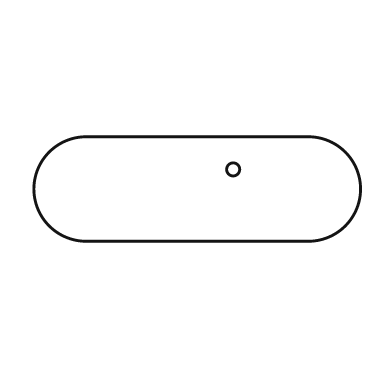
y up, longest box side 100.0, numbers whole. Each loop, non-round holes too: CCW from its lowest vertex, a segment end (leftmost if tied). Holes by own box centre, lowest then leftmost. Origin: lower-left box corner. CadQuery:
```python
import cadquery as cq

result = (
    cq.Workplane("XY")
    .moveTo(16.0, 0.0)
    .lineTo(84.0, 0.0)
    .threePointArc((100.0, 16.0), (84.0, 32.0))
    .lineTo(16.0, 32.0)
    .threePointArc((0.0, 16.0), (16.0, 0.0))
    .close()
    .moveTo(61.0, 22.0)
    .circle(2.0)
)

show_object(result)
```